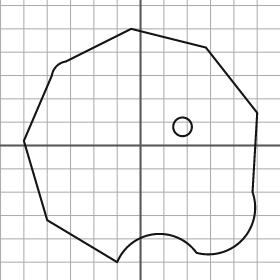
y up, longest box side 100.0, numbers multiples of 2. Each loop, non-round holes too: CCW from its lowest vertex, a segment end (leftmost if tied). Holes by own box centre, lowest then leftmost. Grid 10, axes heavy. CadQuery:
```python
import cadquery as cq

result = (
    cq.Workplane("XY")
    .moveTo(-10.0, -50.0)
    .threePointArc((6.0, -38.0), (24.0, -46.0))
    .threePointArc((44.0, -40.0), (48.0, -20.0))
    .lineTo(50.0, 14.0)
    .lineTo(28.0, 42.0)
    .lineTo(-4.0, 50.0)
    .lineTo(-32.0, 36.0)
    .threePointArc((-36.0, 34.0), (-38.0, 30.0))
    .lineTo(-50.0, 2.0)
    .lineTo(-40.0, -32.0)
    .close()
    .moveTo(18.0, 8.0)
    .circle(4.0)
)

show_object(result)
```